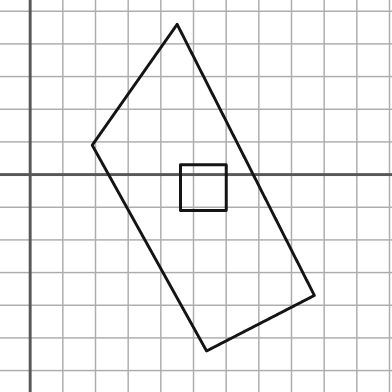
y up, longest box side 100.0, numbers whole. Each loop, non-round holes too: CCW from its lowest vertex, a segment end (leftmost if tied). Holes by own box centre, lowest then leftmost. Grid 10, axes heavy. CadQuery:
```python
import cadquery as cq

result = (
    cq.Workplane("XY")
    .moveTo(54.0, -54.0)
    .lineTo(87.0, -37.0)
    .lineTo(45.0, 46.0)
    .lineTo(19.0, 9.0)
    .close()
    .moveTo(46.0, -11.0)
    .lineTo(60.0, -11.0)
    .lineTo(60.0, 3.0)
    .lineTo(46.0, 3.0)
    .close()
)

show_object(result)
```